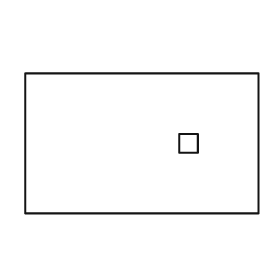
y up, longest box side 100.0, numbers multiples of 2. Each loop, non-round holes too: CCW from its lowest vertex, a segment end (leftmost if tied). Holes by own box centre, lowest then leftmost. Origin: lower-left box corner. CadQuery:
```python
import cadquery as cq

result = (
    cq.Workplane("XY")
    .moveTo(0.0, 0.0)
    .lineTo(100.0, 0.0)
    .lineTo(100.0, 60.0)
    .lineTo(0.0, 60.0)
    .close()
    .moveTo(66.0, 26.0)
    .lineTo(74.0, 26.0)
    .lineTo(74.0, 34.0)
    .lineTo(66.0, 34.0)
    .close()
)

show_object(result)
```